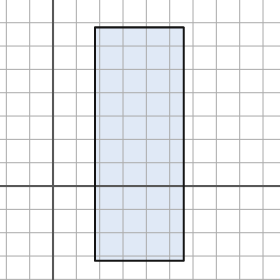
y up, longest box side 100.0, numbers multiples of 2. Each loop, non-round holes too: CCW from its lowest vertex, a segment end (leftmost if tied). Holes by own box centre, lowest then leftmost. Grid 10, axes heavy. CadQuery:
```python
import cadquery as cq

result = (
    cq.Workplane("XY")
    .moveTo(18.0, -32.0)
    .lineTo(56.0, -32.0)
    .lineTo(56.0, 68.0)
    .lineTo(18.0, 68.0)
    .close()
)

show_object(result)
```